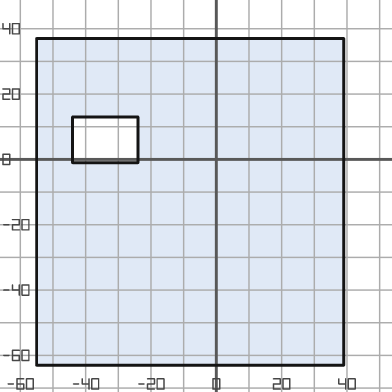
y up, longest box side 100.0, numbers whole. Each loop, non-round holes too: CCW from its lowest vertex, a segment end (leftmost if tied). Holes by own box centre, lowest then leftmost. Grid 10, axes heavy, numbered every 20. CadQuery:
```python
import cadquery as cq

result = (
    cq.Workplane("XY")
    .moveTo(-55.0, -63.0)
    .lineTo(39.0, -63.0)
    .lineTo(39.0, 37.0)
    .lineTo(-55.0, 37.0)
    .close()
    .moveTo(-44.0, -1.0)
    .lineTo(-24.0, -1.0)
    .lineTo(-24.0, 13.0)
    .lineTo(-44.0, 13.0)
    .close()
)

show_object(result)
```